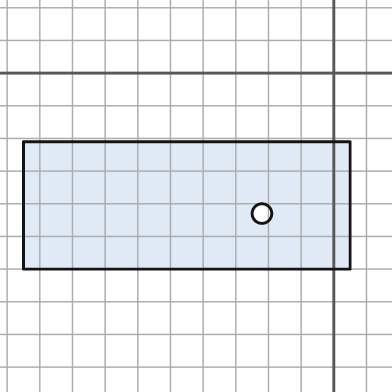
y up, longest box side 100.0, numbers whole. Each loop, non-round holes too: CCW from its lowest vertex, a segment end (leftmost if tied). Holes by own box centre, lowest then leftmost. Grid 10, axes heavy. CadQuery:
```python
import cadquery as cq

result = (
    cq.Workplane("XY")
    .moveTo(-95.0, -60.0)
    .lineTo(5.0, -60.0)
    .lineTo(5.0, -21.0)
    .lineTo(-95.0, -21.0)
    .close()
    .moveTo(-22.0, -43.0)
    .circle(3.0)
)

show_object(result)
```